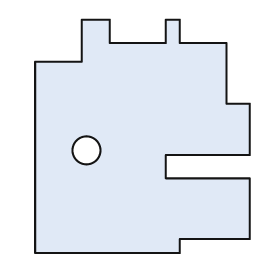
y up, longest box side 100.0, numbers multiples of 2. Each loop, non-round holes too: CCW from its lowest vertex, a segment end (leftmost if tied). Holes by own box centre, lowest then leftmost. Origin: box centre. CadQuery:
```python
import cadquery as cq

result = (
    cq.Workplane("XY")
    .moveTo(-46.0, -50.0)
    .lineTo(16.0, -50.0)
    .lineTo(16.0, -44.0)
    .lineTo(46.0, -44.0)
    .lineTo(46.0, -18.0)
    .lineTo(10.0, -18.0)
    .lineTo(10.0, -8.0)
    .lineTo(46.0, -8.0)
    .lineTo(46.0, 14.0)
    .lineTo(36.0, 14.0)
    .lineTo(36.0, 40.0)
    .lineTo(16.0, 40.0)
    .lineTo(16.0, 50.0)
    .lineTo(10.0, 50.0)
    .lineTo(10.0, 40.0)
    .lineTo(-14.0, 40.0)
    .lineTo(-14.0, 50.0)
    .lineTo(-26.0, 50.0)
    .lineTo(-26.0, 32.0)
    .lineTo(-46.0, 32.0)
    .close()
    .moveTo(-24.0, -6.0)
    .circle(6.0)
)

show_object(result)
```